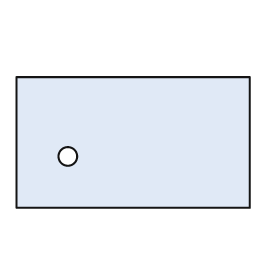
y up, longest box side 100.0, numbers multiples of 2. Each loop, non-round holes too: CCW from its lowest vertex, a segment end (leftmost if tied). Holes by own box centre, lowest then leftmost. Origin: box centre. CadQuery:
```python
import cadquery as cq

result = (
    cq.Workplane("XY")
    .moveTo(-50.0, -28.0)
    .lineTo(50.0, -28.0)
    .lineTo(50.0, 28.0)
    .lineTo(-50.0, 28.0)
    .close()
    .moveTo(-28.0, -6.0)
    .circle(4.0)
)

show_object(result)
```